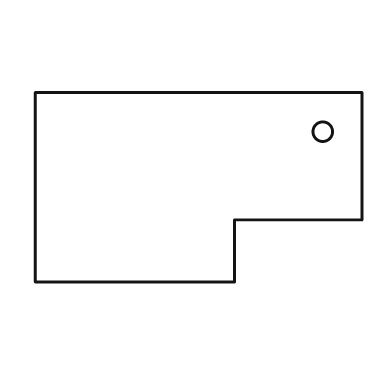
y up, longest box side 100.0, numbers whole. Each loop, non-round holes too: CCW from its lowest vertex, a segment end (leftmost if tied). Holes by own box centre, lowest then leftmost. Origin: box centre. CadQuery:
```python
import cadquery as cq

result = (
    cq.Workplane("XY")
    .moveTo(-50.0, -29.0)
    .lineTo(11.0, -29.0)
    .lineTo(11.0, -10.0)
    .lineTo(50.0, -10.0)
    .lineTo(50.0, 29.0)
    .lineTo(-50.0, 29.0)
    .close()
    .moveTo(38.0, 17.0)
    .circle(3.0)
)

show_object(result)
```